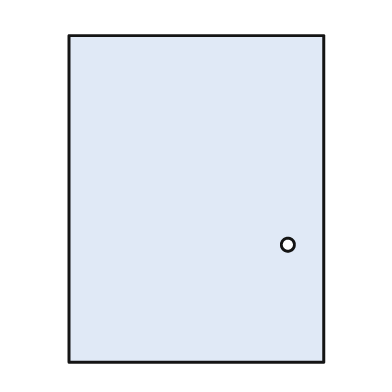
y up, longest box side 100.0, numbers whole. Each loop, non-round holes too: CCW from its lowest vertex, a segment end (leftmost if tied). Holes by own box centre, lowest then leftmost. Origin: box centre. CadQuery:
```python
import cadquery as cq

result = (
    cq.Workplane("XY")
    .moveTo(-39.0, -50.0)
    .lineTo(39.0, -50.0)
    .lineTo(39.0, 50.0)
    .lineTo(-39.0, 50.0)
    .close()
    .moveTo(28.0, -14.0)
    .circle(2.0)
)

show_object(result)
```